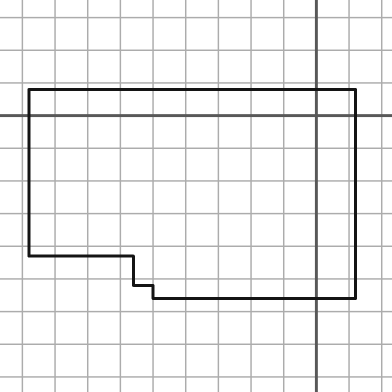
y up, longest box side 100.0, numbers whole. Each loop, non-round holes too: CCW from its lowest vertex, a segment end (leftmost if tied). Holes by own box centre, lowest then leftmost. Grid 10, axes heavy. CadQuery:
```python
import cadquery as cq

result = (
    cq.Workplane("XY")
    .moveTo(-50.0, -56.0)
    .lineTo(12.0, -56.0)
    .lineTo(12.0, 8.0)
    .lineTo(-88.0, 8.0)
    .lineTo(-88.0, -43.0)
    .lineTo(-56.0, -43.0)
    .lineTo(-56.0, -52.0)
    .lineTo(-50.0, -52.0)
    .close()
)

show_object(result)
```